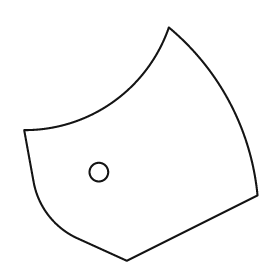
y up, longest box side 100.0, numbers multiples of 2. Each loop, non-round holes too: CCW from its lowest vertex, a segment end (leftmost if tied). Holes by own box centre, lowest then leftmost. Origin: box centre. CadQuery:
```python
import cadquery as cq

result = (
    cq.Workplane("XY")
    .moveTo(-6.0, -50.0)
    .lineTo(50.0, -22.0)
    .threePointArc((38.0, 18.0), (12.0, 50.0))
    .threePointArc((-12.0, 18.0), (-50.0, 6.0))
    .lineTo(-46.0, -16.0)
    .threePointArc((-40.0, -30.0), (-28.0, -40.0))
    .close()
    .moveTo(-18.0, -12.0)
    .circle(4.0)
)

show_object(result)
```